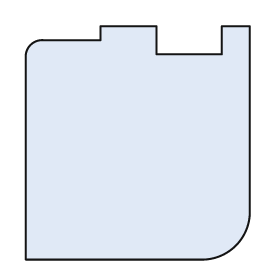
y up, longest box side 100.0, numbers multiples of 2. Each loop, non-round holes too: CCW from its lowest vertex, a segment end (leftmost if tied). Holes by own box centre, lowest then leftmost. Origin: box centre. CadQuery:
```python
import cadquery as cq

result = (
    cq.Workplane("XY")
    .moveTo(-48.0, -50.0)
    .lineTo(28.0, -50.0)
    .threePointArc((42.0, -44.0), (48.0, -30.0))
    .lineTo(48.0, 50.0)
    .lineTo(36.0, 50.0)
    .lineTo(36.0, 38.0)
    .lineTo(8.0, 38.0)
    .lineTo(8.0, 50.0)
    .lineTo(-16.0, 50.0)
    .lineTo(-16.0, 44.0)
    .lineTo(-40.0, 44.0)
    .threePointArc((-46.0, 42.0), (-48.0, 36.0))
    .close()
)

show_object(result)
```